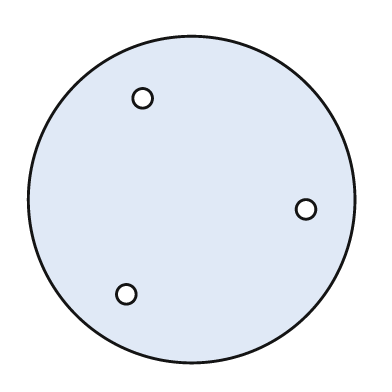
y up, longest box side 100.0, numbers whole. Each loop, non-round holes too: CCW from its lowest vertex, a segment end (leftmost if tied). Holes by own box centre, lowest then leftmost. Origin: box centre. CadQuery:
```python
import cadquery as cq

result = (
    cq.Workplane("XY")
    .moveTo(0.0, 0.0)
    .circle(50.0)
    .moveTo(-20.0, -29.0)
    .circle(3.0)
    .moveTo(35.0, -3.0)
    .circle(3.0)
    .moveTo(-15.0, 31.0)
    .circle(3.0)
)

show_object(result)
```